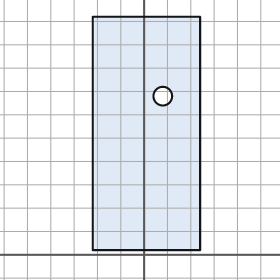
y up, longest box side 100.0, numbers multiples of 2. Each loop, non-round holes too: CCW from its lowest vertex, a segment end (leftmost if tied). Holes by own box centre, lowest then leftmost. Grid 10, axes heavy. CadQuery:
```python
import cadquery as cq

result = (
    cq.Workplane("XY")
    .moveTo(-22.0, 2.0)
    .lineTo(24.0, 2.0)
    .lineTo(24.0, 102.0)
    .lineTo(-22.0, 102.0)
    .close()
    .moveTo(8.0, 68.0)
    .circle(4.0)
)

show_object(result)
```